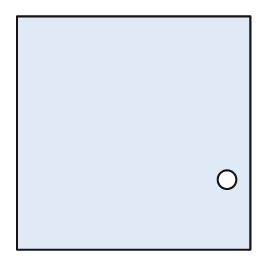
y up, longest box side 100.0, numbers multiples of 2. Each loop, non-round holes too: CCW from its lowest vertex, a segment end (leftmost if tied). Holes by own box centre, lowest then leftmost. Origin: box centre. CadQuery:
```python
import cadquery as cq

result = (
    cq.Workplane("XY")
    .moveTo(-50.0, -50.0)
    .lineTo(50.0, -50.0)
    .lineTo(50.0, 50.0)
    .lineTo(-50.0, 50.0)
    .close()
    .moveTo(40.0, -20.0)
    .circle(4.0)
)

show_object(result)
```